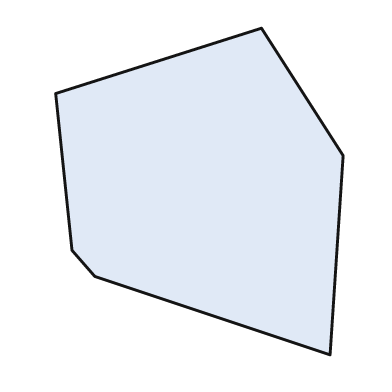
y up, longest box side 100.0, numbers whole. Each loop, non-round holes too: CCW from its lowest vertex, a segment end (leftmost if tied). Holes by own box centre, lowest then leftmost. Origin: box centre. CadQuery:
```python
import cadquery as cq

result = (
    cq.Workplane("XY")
    .moveTo(40.0, -50.0)
    .lineTo(44.0, 11.0)
    .lineTo(19.0, 50.0)
    .lineTo(-44.0, 30.0)
    .lineTo(-39.0, -18.0)
    .lineTo(-32.0, -26.0)
    .close()
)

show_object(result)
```